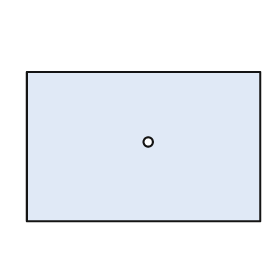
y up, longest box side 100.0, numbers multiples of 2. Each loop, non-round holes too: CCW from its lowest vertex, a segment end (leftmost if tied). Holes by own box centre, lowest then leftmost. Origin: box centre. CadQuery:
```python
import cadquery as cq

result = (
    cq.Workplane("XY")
    .moveTo(-50.0, -32.0)
    .lineTo(50.0, -32.0)
    .lineTo(50.0, 32.0)
    .lineTo(-50.0, 32.0)
    .close()
    .moveTo(2.0, 2.0)
    .circle(2.0)
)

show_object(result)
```